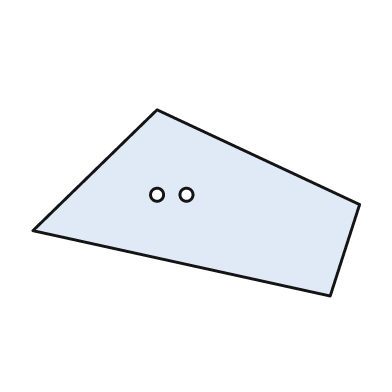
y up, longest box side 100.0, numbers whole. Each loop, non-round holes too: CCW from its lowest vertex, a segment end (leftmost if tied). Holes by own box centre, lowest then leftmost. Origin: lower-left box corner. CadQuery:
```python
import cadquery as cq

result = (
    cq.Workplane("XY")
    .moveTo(91.0, 0.0)
    .lineTo(100.0, 28.0)
    .lineTo(38.0, 57.0)
    .lineTo(0.0, 20.0)
    .close()
    .moveTo(38.0, 31.0)
    .circle(2.0)
    .moveTo(47.0, 31.0)
    .circle(2.0)
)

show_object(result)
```